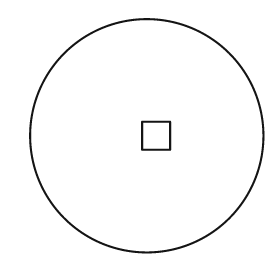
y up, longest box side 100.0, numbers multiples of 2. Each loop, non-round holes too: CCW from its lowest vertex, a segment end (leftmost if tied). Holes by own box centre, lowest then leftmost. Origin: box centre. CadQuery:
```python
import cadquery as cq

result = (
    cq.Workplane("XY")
    .moveTo(0.0, 0.0)
    .circle(50.0)
    .moveTo(-2.0, -6.0)
    .lineTo(10.0, -6.0)
    .lineTo(10.0, 6.0)
    .lineTo(-2.0, 6.0)
    .close()
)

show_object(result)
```